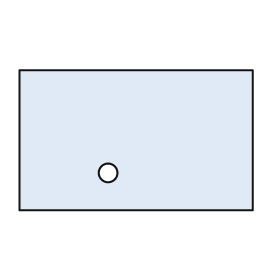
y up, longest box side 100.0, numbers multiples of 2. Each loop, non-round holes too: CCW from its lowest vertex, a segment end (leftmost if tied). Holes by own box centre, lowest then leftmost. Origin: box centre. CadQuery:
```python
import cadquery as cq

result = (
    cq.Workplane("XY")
    .moveTo(-50.0, -30.0)
    .lineTo(50.0, -30.0)
    .lineTo(50.0, 30.0)
    .lineTo(-50.0, 30.0)
    .close()
    .moveTo(-12.0, -14.0)
    .circle(4.0)
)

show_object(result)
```